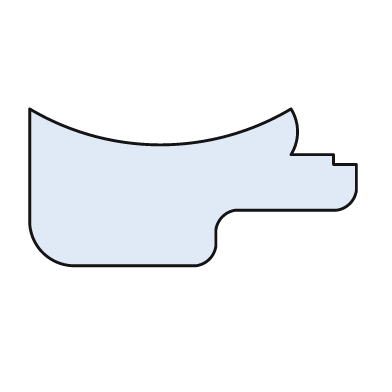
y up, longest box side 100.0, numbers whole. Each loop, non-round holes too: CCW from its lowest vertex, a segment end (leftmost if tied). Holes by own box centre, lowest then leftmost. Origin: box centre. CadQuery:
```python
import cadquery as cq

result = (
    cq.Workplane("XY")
    .moveTo(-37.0, -24.0)
    .lineTo(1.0, -24.0)
    .threePointArc((5.0, -22.0), (7.0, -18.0))
    .lineTo(7.0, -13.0)
    .threePointArc((9.0, -9.0), (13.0, -7.0))
    .lineTo(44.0, -7.0)
    .threePointArc((48.0, -5.0), (50.0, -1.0))
    .lineTo(50.0, 7.0)
    .lineTo(43.0, 7.0)
    .lineTo(43.0, 10.0)
    .lineTo(30.0, 10.0)
    .threePointArc((32.0, 17.0), (30.0, 24.0))
    .threePointArc((-10.0, 13.0), (-50.0, 24.0))
    .lineTo(-50.0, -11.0)
    .threePointArc((-46.0, -20.0), (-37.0, -24.0))
    .close()
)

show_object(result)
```